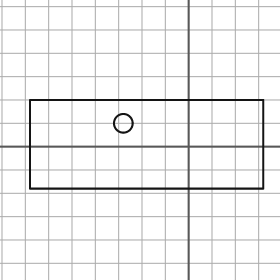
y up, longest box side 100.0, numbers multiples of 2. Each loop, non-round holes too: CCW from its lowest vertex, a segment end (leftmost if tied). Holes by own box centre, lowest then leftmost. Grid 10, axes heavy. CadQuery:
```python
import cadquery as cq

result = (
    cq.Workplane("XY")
    .moveTo(-68.0, -18.0)
    .lineTo(32.0, -18.0)
    .lineTo(32.0, 20.0)
    .lineTo(-68.0, 20.0)
    .close()
    .moveTo(-28.0, 10.0)
    .circle(4.0)
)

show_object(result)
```